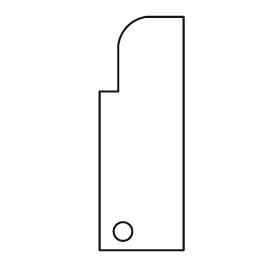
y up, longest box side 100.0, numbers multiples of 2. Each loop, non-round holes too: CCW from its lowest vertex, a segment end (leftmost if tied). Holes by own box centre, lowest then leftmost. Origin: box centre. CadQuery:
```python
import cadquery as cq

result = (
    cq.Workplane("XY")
    .moveTo(-18.0, -50.0)
    .lineTo(18.0, -50.0)
    .lineTo(18.0, 50.0)
    .lineTo(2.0, 50.0)
    .threePointArc((-6.0, 46.0), (-10.0, 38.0))
    .lineTo(-10.0, 18.0)
    .lineTo(-18.0, 18.0)
    .close()
    .moveTo(-8.0, -42.0)
    .circle(4.0)
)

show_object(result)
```